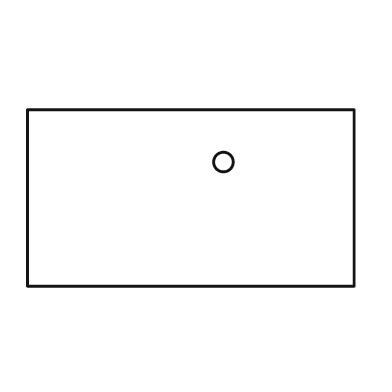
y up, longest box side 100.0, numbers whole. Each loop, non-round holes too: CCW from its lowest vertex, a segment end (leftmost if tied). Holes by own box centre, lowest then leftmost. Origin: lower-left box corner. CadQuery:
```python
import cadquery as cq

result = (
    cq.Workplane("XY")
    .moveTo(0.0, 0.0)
    .lineTo(100.0, 0.0)
    .lineTo(100.0, 54.0)
    .lineTo(0.0, 54.0)
    .close()
    .moveTo(60.0, 38.0)
    .circle(3.0)
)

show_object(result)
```